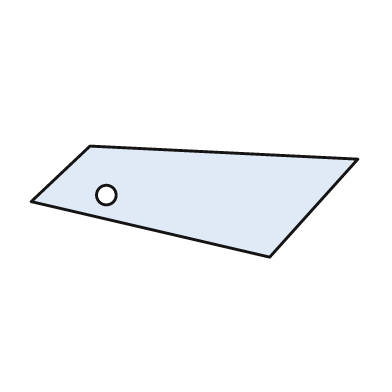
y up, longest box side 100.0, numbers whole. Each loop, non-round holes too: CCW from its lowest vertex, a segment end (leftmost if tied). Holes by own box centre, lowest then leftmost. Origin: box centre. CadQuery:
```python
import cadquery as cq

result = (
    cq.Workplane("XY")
    .moveTo(23.0, -17.0)
    .lineTo(50.0, 13.0)
    .lineTo(-32.0, 17.0)
    .lineTo(-50.0, 0.0)
    .close()
    .moveTo(-27.0, 2.0)
    .circle(3.0)
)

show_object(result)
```